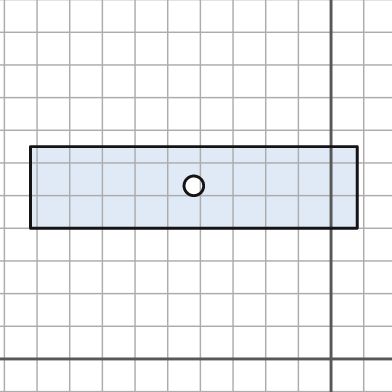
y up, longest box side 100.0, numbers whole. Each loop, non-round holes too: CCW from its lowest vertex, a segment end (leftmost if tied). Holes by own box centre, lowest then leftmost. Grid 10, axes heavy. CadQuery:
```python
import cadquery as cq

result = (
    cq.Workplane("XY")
    .moveTo(-92.0, 40.0)
    .lineTo(8.0, 40.0)
    .lineTo(8.0, 65.0)
    .lineTo(-92.0, 65.0)
    .close()
    .moveTo(-42.0, 53.0)
    .circle(3.0)
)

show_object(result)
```